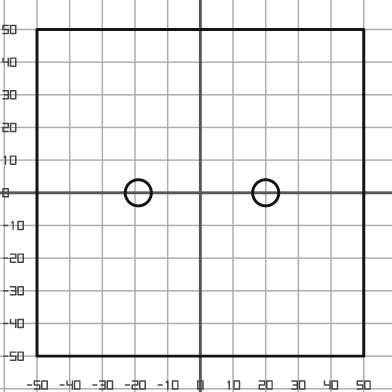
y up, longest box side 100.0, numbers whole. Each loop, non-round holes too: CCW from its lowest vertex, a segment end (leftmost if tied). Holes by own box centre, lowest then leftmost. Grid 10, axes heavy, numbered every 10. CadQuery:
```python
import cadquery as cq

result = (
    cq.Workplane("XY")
    .moveTo(-50.0, -50.0)
    .lineTo(50.0, -50.0)
    .lineTo(50.0, 50.0)
    .lineTo(-50.0, 50.0)
    .close()
    .moveTo(-19.0, 0.0)
    .circle(4.0)
    .moveTo(20.0, 0.0)
    .circle(4.0)
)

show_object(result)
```